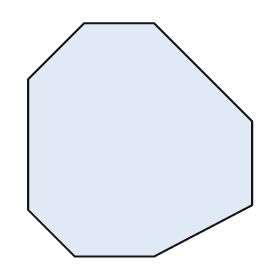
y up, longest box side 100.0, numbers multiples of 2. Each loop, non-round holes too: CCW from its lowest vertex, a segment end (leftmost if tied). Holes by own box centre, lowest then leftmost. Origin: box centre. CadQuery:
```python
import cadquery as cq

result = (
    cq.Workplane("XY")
    .moveTo(-28.0, -50.0)
    .lineTo(6.0, -50.0)
    .lineTo(48.0, -28.0)
    .lineTo(48.0, 8.0)
    .lineTo(6.0, 50.0)
    .lineTo(-24.0, 50.0)
    .lineTo(-48.0, 26.0)
    .lineTo(-48.0, -30.0)
    .close()
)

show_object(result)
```